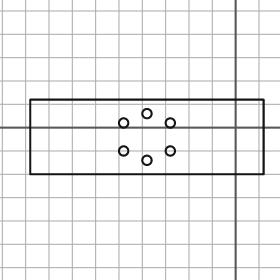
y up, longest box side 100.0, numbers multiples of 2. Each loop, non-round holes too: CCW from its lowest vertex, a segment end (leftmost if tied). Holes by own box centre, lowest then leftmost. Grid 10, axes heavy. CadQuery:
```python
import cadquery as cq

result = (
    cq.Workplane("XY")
    .moveTo(-88.0, -20.0)
    .lineTo(12.0, -20.0)
    .lineTo(12.0, 12.0)
    .lineTo(-88.0, 12.0)
    .close()
    .moveTo(-38.0, -14.0)
    .circle(2.0)
    .moveTo(-48.0, -10.0)
    .circle(2.0)
    .moveTo(-28.0, -10.0)
    .circle(2.0)
    .moveTo(-48.0, 2.0)
    .circle(2.0)
    .moveTo(-28.0, 2.0)
    .circle(2.0)
    .moveTo(-38.0, 6.0)
    .circle(2.0)
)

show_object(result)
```